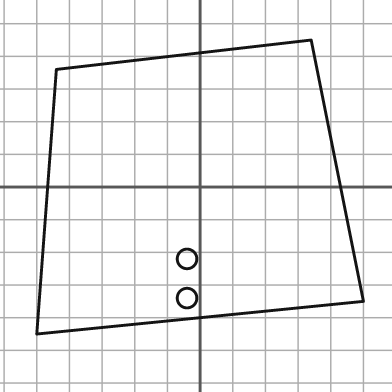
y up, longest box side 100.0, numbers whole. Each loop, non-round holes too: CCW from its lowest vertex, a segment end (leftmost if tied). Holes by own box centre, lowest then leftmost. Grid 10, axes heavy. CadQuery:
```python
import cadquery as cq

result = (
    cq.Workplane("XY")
    .moveTo(-50.0, -45.0)
    .lineTo(50.0, -35.0)
    .lineTo(34.0, 45.0)
    .lineTo(-44.0, 36.0)
    .close()
    .moveTo(-4.0, -34.0)
    .circle(3.0)
    .moveTo(-4.0, -22.0)
    .circle(3.0)
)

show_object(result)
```